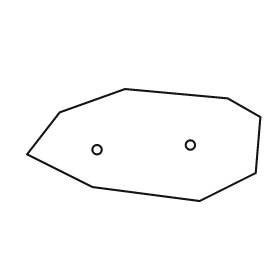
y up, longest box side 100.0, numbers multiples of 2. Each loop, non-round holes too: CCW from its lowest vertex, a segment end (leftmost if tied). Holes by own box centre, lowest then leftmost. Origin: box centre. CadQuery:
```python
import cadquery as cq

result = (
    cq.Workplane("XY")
    .moveTo(24.0, -24.0)
    .lineTo(48.0, -12.0)
    .lineTo(50.0, 12.0)
    .lineTo(36.0, 20.0)
    .lineTo(-8.0, 24.0)
    .lineTo(-36.0, 14.0)
    .lineTo(-50.0, -4.0)
    .lineTo(-22.0, -18.0)
    .close()
    .moveTo(-20.0, -2.0)
    .circle(2.0)
    .moveTo(20.0, 0.0)
    .circle(2.0)
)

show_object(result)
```